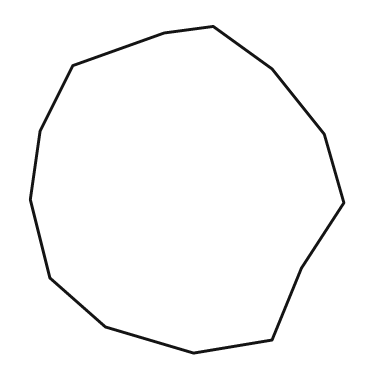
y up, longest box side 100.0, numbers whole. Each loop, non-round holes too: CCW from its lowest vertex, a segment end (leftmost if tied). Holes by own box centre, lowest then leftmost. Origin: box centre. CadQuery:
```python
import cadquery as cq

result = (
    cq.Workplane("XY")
    .moveTo(2.0, -50.0)
    .lineTo(26.0, -46.0)
    .lineTo(35.0, -24.0)
    .lineTo(48.0, -4.0)
    .lineTo(42.0, 17.0)
    .lineTo(26.0, 37.0)
    .lineTo(8.0, 50.0)
    .lineTo(-7.0, 48.0)
    .lineTo(-35.0, 38.0)
    .lineTo(-45.0, 18.0)
    .lineTo(-48.0, -3.0)
    .lineTo(-42.0, -27.0)
    .lineTo(-25.0, -42.0)
    .close()
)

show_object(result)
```